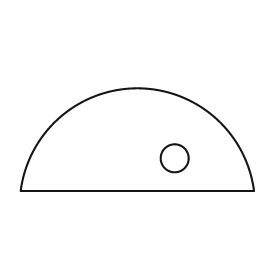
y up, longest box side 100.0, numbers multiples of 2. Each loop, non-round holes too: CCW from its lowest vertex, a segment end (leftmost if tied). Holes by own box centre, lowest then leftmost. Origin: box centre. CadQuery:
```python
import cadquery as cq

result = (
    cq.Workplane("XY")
    .moveTo(-50.0, -22.0)
    .lineTo(50.0, -22.0)
    .threePointArc((0.0, 22.0), (-50.0, -22.0))
    .close()
    .moveTo(16.0, -8.0)
    .circle(6.0)
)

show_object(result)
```